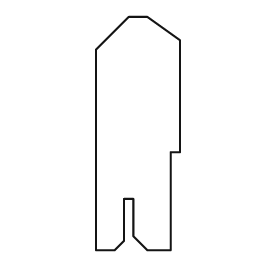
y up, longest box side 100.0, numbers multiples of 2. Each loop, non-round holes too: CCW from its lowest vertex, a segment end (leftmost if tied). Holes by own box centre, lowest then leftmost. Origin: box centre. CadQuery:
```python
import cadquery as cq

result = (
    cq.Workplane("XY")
    .moveTo(-18.0, -50.0)
    .lineTo(-10.0, -50.0)
    .lineTo(-6.0, -46.0)
    .lineTo(-6.0, -28.0)
    .lineTo(-2.0, -28.0)
    .lineTo(-2.0, -44.0)
    .lineTo(4.0, -50.0)
    .lineTo(14.0, -50.0)
    .lineTo(14.0, -8.0)
    .lineTo(18.0, -8.0)
    .lineTo(18.0, 40.0)
    .lineTo(4.0, 50.0)
    .lineTo(-4.0, 50.0)
    .lineTo(-18.0, 36.0)
    .close()
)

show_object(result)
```